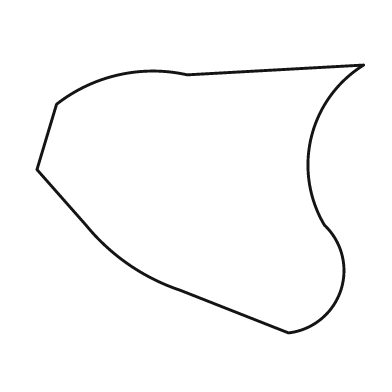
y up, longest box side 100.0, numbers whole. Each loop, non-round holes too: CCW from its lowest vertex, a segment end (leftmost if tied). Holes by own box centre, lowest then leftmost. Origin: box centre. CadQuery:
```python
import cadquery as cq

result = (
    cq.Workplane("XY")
    .moveTo(27.0, -41.0)
    .threePointArc((43.0, -28.0), (38.0, -8.0))
    .threePointArc((34.0, 19.0), (50.0, 41.0))
    .lineTo(-4.0, 38.0)
    .threePointArc((-25.0, 38.0), (-44.0, 29.0))
    .lineTo(-50.0, 9.0)
    .lineTo(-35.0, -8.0)
    .threePointArc((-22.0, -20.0), (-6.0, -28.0))
    .close()
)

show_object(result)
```